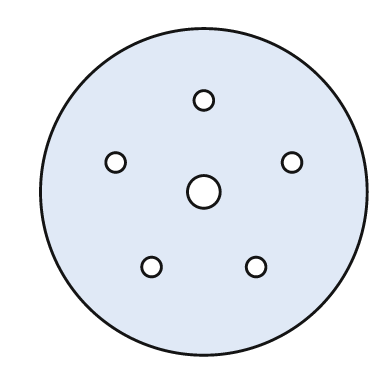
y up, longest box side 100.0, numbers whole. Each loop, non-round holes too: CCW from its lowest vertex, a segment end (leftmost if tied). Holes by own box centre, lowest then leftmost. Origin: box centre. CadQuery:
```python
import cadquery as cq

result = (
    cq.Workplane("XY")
    .moveTo(0.0, 0.0)
    .circle(50.0)
    .moveTo(-16.0, -23.0)
    .circle(3.0)
    .moveTo(16.0, -23.0)
    .circle(3.0)
    .moveTo(0.0, 0.0)
    .circle(5.0)
    .moveTo(-27.0, 9.0)
    .circle(3.0)
    .moveTo(27.0, 9.0)
    .circle(3.0)
    .moveTo(0.0, 28.0)
    .circle(3.0)
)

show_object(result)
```